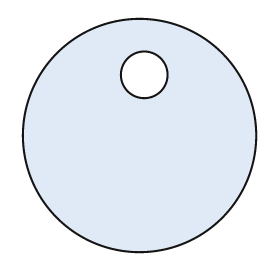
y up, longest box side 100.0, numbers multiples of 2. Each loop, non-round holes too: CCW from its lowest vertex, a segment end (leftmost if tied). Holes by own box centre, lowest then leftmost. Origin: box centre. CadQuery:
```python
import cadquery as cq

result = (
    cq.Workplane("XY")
    .moveTo(0.0, 0.0)
    .circle(50.0)
    .moveTo(2.0, 26.0)
    .circle(10.0)
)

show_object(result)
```